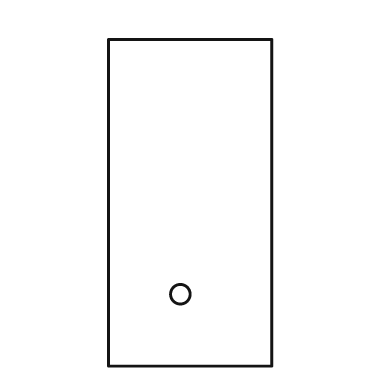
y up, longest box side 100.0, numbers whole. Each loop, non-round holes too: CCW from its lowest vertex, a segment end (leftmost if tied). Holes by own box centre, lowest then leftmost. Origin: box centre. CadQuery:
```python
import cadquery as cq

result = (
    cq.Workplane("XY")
    .moveTo(-25.0, -50.0)
    .lineTo(25.0, -50.0)
    .lineTo(25.0, 50.0)
    .lineTo(-25.0, 50.0)
    .close()
    .moveTo(-3.0, -28.0)
    .circle(3.0)
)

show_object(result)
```